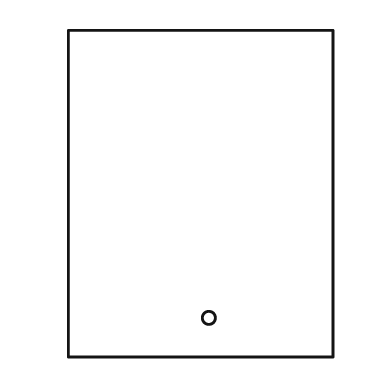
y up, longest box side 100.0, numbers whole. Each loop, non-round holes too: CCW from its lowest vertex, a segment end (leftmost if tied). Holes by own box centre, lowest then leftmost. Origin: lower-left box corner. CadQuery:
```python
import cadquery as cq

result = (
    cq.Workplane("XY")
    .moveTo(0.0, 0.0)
    .lineTo(81.0, 0.0)
    .lineTo(81.0, 100.0)
    .lineTo(0.0, 100.0)
    .close()
    .moveTo(43.0, 12.0)
    .circle(2.0)
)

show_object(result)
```